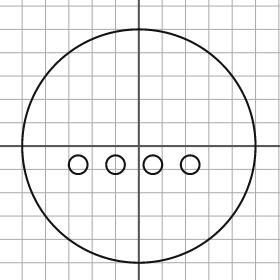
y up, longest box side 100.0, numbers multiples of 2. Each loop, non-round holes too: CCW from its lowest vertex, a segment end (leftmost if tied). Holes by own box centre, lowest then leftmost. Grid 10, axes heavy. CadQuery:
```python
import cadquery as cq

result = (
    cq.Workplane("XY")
    .moveTo(0.0, 0.0)
    .circle(50.0)
    .moveTo(-26.0, -8.0)
    .circle(4.0)
    .moveTo(-10.0, -8.0)
    .circle(4.0)
    .moveTo(6.0, -8.0)
    .circle(4.0)
    .moveTo(22.0, -8.0)
    .circle(4.0)
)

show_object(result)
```